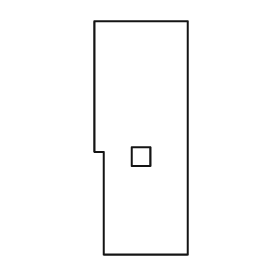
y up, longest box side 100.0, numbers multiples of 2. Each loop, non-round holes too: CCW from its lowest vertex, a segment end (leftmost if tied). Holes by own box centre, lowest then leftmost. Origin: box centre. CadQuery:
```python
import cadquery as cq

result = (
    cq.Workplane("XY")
    .moveTo(-16.0, -50.0)
    .lineTo(20.0, -50.0)
    .lineTo(20.0, 50.0)
    .lineTo(-20.0, 50.0)
    .lineTo(-20.0, -6.0)
    .lineTo(-16.0, -6.0)
    .close()
    .moveTo(-4.0, -12.0)
    .lineTo(4.0, -12.0)
    .lineTo(4.0, -4.0)
    .lineTo(-4.0, -4.0)
    .close()
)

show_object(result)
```